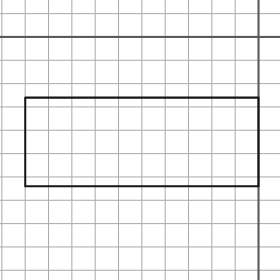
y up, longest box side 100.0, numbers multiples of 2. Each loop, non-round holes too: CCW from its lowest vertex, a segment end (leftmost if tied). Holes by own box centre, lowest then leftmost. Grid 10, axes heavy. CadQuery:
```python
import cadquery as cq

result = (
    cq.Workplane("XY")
    .moveTo(-100.0, -64.0)
    .lineTo(0.0, -64.0)
    .lineTo(0.0, -26.0)
    .lineTo(-100.0, -26.0)
    .close()
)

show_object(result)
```